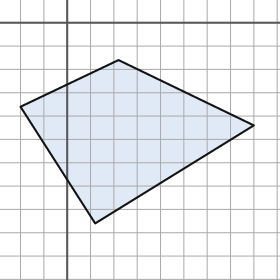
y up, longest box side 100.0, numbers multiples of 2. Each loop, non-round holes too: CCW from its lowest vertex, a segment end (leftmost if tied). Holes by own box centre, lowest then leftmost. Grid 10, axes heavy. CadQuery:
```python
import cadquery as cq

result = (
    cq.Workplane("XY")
    .moveTo(12.0, -86.0)
    .lineTo(80.0, -44.0)
    .lineTo(22.0, -16.0)
    .lineTo(-20.0, -36.0)
    .close()
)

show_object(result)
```